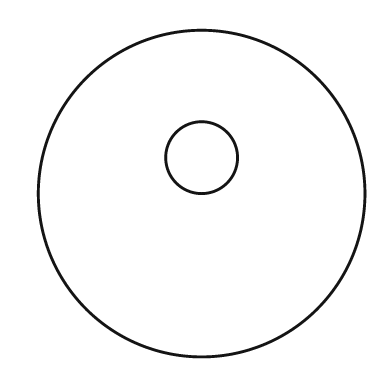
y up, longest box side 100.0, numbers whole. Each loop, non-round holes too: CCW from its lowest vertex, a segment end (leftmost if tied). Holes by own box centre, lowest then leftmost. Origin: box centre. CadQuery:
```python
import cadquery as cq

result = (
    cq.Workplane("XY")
    .moveTo(0.0, 0.0)
    .circle(50.0)
    .moveTo(0.0, 11.0)
    .circle(11.0)
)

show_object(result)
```